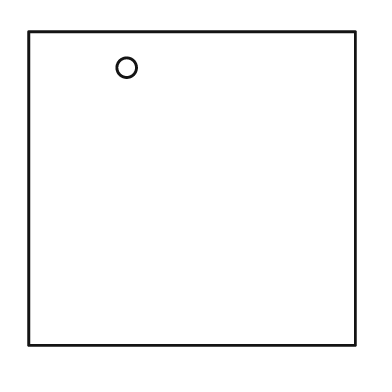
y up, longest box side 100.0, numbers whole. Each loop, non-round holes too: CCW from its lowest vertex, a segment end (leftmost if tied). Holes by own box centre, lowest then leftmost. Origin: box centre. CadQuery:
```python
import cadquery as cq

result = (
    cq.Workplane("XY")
    .moveTo(-50.0, -48.0)
    .lineTo(50.0, -48.0)
    .lineTo(50.0, 48.0)
    .lineTo(-50.0, 48.0)
    .close()
    .moveTo(-20.0, 37.0)
    .circle(3.0)
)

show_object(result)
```